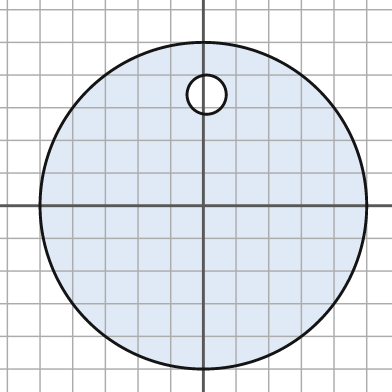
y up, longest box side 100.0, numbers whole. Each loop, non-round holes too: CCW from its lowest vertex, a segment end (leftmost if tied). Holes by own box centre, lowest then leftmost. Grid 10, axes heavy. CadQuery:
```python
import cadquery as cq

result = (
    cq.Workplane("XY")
    .moveTo(0.0, 0.0)
    .circle(50.0)
    .moveTo(1.0, 34.0)
    .circle(6.0)
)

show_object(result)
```